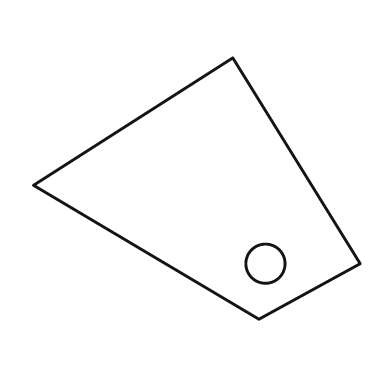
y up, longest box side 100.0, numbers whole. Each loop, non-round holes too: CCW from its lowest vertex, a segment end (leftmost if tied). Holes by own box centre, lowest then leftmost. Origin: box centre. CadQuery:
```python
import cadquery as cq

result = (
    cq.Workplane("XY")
    .moveTo(19.0, -40.0)
    .lineTo(50.0, -23.0)
    .lineTo(11.0, 40.0)
    .lineTo(-50.0, 1.0)
    .close()
    .moveTo(21.0, -23.0)
    .circle(6.0)
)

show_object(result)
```